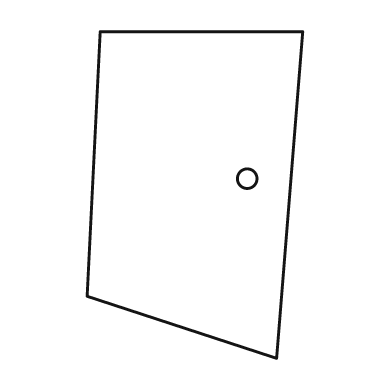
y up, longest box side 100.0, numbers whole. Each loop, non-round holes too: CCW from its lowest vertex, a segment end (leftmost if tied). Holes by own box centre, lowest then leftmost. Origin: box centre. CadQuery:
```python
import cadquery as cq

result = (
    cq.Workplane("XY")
    .moveTo(25.0, -50.0)
    .lineTo(33.0, 50.0)
    .lineTo(-29.0, 50.0)
    .lineTo(-33.0, -31.0)
    .close()
    .moveTo(16.0, 5.0)
    .circle(3.0)
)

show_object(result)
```